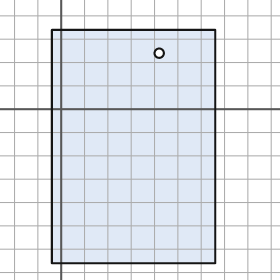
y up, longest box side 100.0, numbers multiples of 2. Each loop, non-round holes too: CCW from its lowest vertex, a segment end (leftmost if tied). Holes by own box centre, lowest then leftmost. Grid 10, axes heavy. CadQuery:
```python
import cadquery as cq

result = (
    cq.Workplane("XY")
    .moveTo(-4.0, -66.0)
    .lineTo(66.0, -66.0)
    .lineTo(66.0, 34.0)
    .lineTo(-4.0, 34.0)
    .close()
    .moveTo(42.0, 24.0)
    .circle(2.0)
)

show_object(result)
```